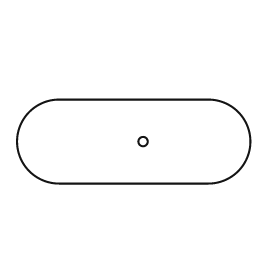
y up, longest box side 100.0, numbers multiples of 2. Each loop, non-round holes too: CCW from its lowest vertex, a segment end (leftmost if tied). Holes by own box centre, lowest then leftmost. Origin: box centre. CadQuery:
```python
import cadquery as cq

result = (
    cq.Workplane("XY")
    .moveTo(-32.0, -18.0)
    .lineTo(32.0, -18.0)
    .threePointArc((50.0, 0.0), (32.0, 18.0))
    .lineTo(-32.0, 18.0)
    .threePointArc((-50.0, 0.0), (-32.0, -18.0))
    .close()
    .moveTo(4.0, 0.0)
    .circle(2.0)
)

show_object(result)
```